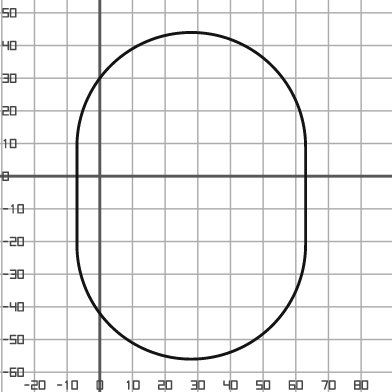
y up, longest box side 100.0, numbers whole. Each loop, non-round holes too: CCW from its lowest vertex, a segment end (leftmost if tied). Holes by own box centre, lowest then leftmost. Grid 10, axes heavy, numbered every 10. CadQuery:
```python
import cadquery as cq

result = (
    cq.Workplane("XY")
    .moveTo(-7.0, -21.0)
    .threePointArc((28.0, -56.0), (63.0, -21.0))
    .lineTo(63.0, 9.0)
    .threePointArc((28.0, 44.0), (-7.0, 9.0))
    .close()
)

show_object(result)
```